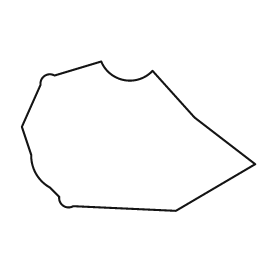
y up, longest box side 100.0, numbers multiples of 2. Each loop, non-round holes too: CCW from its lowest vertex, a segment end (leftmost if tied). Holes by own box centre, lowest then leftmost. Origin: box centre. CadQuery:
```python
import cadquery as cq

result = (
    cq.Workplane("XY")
    .moveTo(16.0, -32.0)
    .lineTo(50.0, -12.0)
    .lineTo(24.0, 8.0)
    .lineTo(6.0, 28.0)
    .threePointArc((-6.0, 24.0), (-16.0, 32.0))
    .lineTo(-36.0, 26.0)
    .threePointArc((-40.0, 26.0), (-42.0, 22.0))
    .lineTo(-50.0, 4.0)
    .lineTo(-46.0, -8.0)
    .threePointArc((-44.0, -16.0), (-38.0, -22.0))
    .lineTo(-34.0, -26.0)
    .threePointArc((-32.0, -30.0), (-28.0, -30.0))
    .close()
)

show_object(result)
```